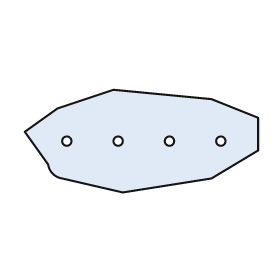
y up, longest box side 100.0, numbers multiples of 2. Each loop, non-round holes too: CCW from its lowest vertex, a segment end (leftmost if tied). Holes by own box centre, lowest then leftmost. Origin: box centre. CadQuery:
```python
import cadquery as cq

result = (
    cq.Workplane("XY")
    .moveTo(-8.0, -22.0)
    .lineTo(30.0, -16.0)
    .lineTo(50.0, -4.0)
    .lineTo(50.0, 10.0)
    .lineTo(30.0, 18.0)
    .lineTo(-12.0, 22.0)
    .lineTo(-36.0, 14.0)
    .lineTo(-50.0, 4.0)
    .lineTo(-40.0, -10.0)
    .threePointArc((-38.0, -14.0), (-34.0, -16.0))
    .close()
    .moveTo(-32.0, 0.0)
    .circle(2.0)
    .moveTo(-10.0, 0.0)
    .circle(2.0)
    .moveTo(12.0, 0.0)
    .circle(2.0)
    .moveTo(34.0, 0.0)
    .circle(2.0)
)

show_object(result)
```